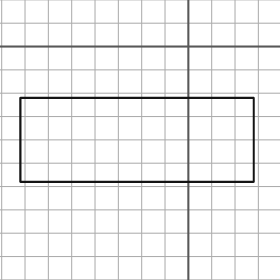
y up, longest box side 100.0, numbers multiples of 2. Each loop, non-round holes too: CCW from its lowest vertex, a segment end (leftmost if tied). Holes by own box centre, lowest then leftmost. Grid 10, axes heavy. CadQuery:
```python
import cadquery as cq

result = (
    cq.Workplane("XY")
    .moveTo(-72.0, -58.0)
    .lineTo(28.0, -58.0)
    .lineTo(28.0, -22.0)
    .lineTo(-72.0, -22.0)
    .close()
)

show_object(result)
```